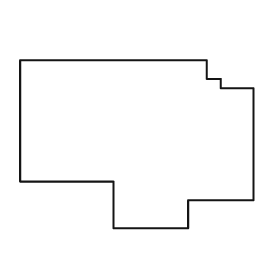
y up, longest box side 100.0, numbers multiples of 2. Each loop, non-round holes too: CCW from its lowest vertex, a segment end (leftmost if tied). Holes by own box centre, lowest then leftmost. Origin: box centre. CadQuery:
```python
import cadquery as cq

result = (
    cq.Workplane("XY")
    .moveTo(-10.0, -36.0)
    .lineTo(22.0, -36.0)
    .lineTo(22.0, -24.0)
    .lineTo(50.0, -24.0)
    .lineTo(50.0, 24.0)
    .lineTo(36.0, 24.0)
    .lineTo(36.0, 28.0)
    .lineTo(30.0, 28.0)
    .lineTo(30.0, 36.0)
    .lineTo(-50.0, 36.0)
    .lineTo(-50.0, -16.0)
    .lineTo(-10.0, -16.0)
    .close()
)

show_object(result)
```